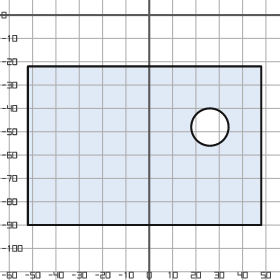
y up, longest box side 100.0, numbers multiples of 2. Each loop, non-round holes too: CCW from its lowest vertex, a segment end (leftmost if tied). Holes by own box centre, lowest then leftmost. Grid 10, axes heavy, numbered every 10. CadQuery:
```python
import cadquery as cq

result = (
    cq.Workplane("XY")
    .moveTo(-52.0, -90.0)
    .lineTo(48.0, -90.0)
    .lineTo(48.0, -22.0)
    .lineTo(-52.0, -22.0)
    .close()
    .moveTo(26.0, -48.0)
    .circle(8.0)
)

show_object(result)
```